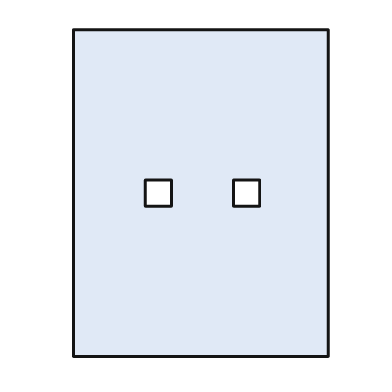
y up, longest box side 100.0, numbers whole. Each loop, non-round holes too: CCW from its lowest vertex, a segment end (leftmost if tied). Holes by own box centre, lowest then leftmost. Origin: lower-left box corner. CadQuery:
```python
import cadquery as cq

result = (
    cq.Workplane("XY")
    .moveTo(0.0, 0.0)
    .lineTo(78.0, 0.0)
    .lineTo(78.0, 100.0)
    .lineTo(0.0, 100.0)
    .close()
    .moveTo(22.0, 46.0)
    .lineTo(30.0, 46.0)
    .lineTo(30.0, 54.0)
    .lineTo(22.0, 54.0)
    .close()
    .moveTo(49.0, 46.0)
    .lineTo(57.0, 46.0)
    .lineTo(57.0, 54.0)
    .lineTo(49.0, 54.0)
    .close()
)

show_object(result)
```